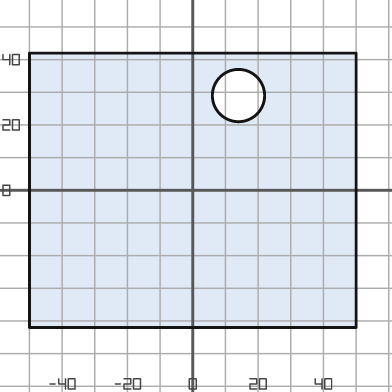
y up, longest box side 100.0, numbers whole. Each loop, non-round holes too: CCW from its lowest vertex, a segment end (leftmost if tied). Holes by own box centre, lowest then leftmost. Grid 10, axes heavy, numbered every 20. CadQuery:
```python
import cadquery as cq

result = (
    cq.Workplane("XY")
    .moveTo(-50.0, -42.0)
    .lineTo(50.0, -42.0)
    .lineTo(50.0, 42.0)
    .lineTo(-50.0, 42.0)
    .close()
    .moveTo(14.0, 29.0)
    .circle(8.0)
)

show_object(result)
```